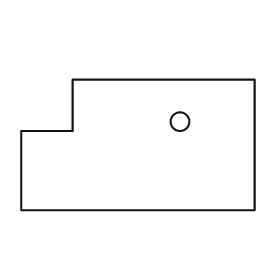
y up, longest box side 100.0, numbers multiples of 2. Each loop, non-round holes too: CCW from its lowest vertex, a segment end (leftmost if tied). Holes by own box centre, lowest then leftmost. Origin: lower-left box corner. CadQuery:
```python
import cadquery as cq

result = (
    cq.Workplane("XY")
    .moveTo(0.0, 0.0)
    .lineTo(100.0, 0.0)
    .lineTo(100.0, 56.0)
    .lineTo(22.0, 56.0)
    .lineTo(22.0, 34.0)
    .lineTo(0.0, 34.0)
    .close()
    .moveTo(68.0, 38.0)
    .circle(4.0)
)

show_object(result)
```